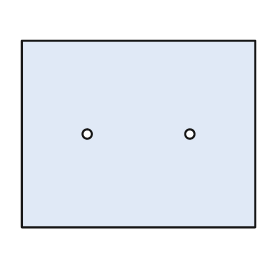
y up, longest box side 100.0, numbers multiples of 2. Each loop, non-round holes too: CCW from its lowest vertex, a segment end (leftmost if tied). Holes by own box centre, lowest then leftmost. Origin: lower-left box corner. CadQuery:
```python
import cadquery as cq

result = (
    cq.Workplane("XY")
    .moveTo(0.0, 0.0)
    .lineTo(100.0, 0.0)
    .lineTo(100.0, 80.0)
    .lineTo(0.0, 80.0)
    .close()
    .moveTo(28.0, 40.0)
    .circle(2.0)
    .moveTo(72.0, 40.0)
    .circle(2.0)
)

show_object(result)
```